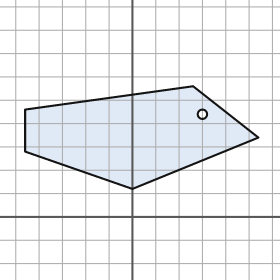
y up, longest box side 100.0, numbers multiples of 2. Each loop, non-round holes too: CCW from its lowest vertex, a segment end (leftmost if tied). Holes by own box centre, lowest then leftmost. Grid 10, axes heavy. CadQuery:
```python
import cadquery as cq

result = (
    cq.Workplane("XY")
    .moveTo(0.0, 12.0)
    .lineTo(54.0, 34.0)
    .lineTo(26.0, 56.0)
    .lineTo(-46.0, 46.0)
    .lineTo(-46.0, 28.0)
    .close()
    .moveTo(30.0, 44.0)
    .circle(2.0)
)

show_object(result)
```